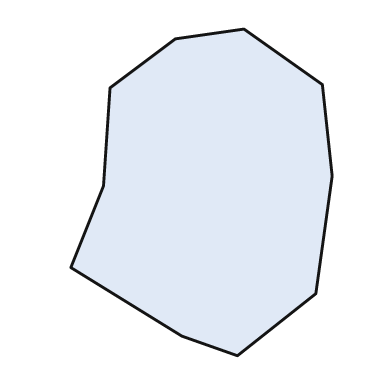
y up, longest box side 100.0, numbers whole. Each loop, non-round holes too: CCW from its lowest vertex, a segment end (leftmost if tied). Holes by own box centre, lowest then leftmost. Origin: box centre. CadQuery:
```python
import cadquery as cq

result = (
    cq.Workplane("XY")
    .moveTo(11.0, -50.0)
    .lineTo(35.0, -31.0)
    .lineTo(40.0, 5.0)
    .lineTo(37.0, 33.0)
    .lineTo(13.0, 50.0)
    .lineTo(-8.0, 47.0)
    .lineTo(-28.0, 32.0)
    .lineTo(-30.0, 2.0)
    .lineTo(-40.0, -23.0)
    .lineTo(-6.0, -44.0)
    .close()
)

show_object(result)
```